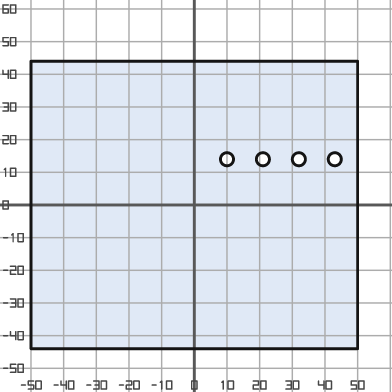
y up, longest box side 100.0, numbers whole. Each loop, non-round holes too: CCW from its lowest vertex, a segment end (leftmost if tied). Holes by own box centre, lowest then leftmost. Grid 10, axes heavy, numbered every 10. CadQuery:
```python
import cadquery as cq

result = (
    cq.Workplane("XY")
    .moveTo(-50.0, -44.0)
    .lineTo(50.0, -44.0)
    .lineTo(50.0, 44.0)
    .lineTo(-50.0, 44.0)
    .close()
    .moveTo(10.0, 14.0)
    .circle(2.0)
    .moveTo(21.0, 14.0)
    .circle(2.0)
    .moveTo(32.0, 14.0)
    .circle(2.0)
    .moveTo(43.0, 14.0)
    .circle(2.0)
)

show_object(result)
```